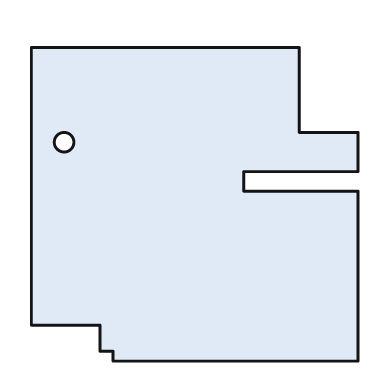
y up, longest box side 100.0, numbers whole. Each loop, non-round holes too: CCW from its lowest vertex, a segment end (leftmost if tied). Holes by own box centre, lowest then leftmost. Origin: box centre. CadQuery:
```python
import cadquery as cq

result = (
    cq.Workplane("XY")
    .moveTo(-25.0, -48.0)
    .lineTo(50.0, -48.0)
    .lineTo(50.0, 4.0)
    .lineTo(15.0, 4.0)
    .lineTo(15.0, 10.0)
    .lineTo(50.0, 10.0)
    .lineTo(50.0, 22.0)
    .lineTo(32.0, 22.0)
    .lineTo(32.0, 48.0)
    .lineTo(-50.0, 48.0)
    .lineTo(-50.0, -37.0)
    .lineTo(-29.0, -37.0)
    .lineTo(-29.0, -45.0)
    .lineTo(-25.0, -45.0)
    .close()
    .moveTo(-40.0, 19.0)
    .circle(3.0)
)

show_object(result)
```